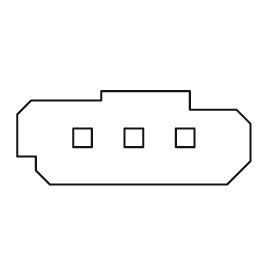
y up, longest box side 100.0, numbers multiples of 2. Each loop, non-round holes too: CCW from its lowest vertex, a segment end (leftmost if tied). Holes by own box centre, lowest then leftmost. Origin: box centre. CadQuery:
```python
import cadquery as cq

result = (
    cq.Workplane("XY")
    .moveTo(-36.0, -20.0)
    .lineTo(40.0, -20.0)
    .lineTo(50.0, -10.0)
    .lineTo(50.0, 6.0)
    .lineTo(44.0, 12.0)
    .lineTo(24.0, 12.0)
    .lineTo(24.0, 20.0)
    .lineTo(-14.0, 20.0)
    .lineTo(-14.0, 16.0)
    .lineTo(-44.0, 16.0)
    .lineTo(-50.0, 10.0)
    .lineTo(-50.0, -8.0)
    .lineTo(-42.0, -8.0)
    .lineTo(-42.0, -14.0)
    .close()
    .moveTo(-26.0, -4.0)
    .lineTo(-18.0, -4.0)
    .lineTo(-18.0, 4.0)
    .lineTo(-26.0, 4.0)
    .close()
    .moveTo(-4.0, -4.0)
    .lineTo(4.0, -4.0)
    .lineTo(4.0, 4.0)
    .lineTo(-4.0, 4.0)
    .close()
    .moveTo(18.0, -4.0)
    .lineTo(26.0, -4.0)
    .lineTo(26.0, 4.0)
    .lineTo(18.0, 4.0)
    .close()
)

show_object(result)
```